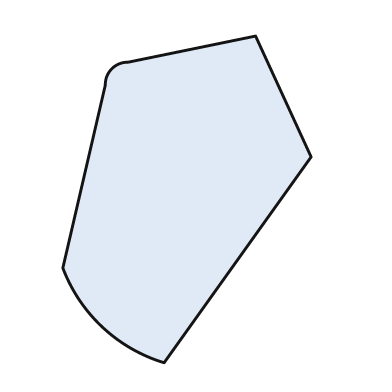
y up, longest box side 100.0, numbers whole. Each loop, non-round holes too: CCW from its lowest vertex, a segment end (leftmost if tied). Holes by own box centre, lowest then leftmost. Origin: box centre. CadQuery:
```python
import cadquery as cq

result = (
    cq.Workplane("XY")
    .moveTo(-7.0, -50.0)
    .lineTo(38.0, 13.0)
    .lineTo(21.0, 50.0)
    .lineTo(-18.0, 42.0)
    .threePointArc((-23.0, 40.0), (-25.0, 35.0))
    .lineTo(-38.0, -21.0)
    .threePointArc((-26.0, -39.0), (-7.0, -50.0))
    .close()
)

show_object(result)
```